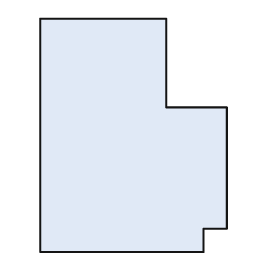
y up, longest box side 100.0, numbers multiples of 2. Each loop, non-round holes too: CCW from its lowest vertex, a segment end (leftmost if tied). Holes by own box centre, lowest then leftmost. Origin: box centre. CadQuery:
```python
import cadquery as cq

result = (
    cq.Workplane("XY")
    .moveTo(-40.0, -50.0)
    .lineTo(30.0, -50.0)
    .lineTo(30.0, -40.0)
    .lineTo(40.0, -40.0)
    .lineTo(40.0, 12.0)
    .lineTo(14.0, 12.0)
    .lineTo(14.0, 50.0)
    .lineTo(-40.0, 50.0)
    .close()
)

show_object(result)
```